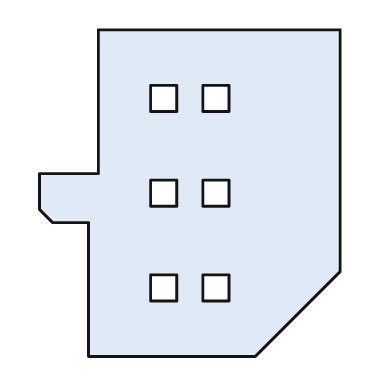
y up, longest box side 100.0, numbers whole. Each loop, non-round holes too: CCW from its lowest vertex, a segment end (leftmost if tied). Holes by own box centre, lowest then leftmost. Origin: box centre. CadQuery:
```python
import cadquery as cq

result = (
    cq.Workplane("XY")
    .moveTo(-31.0, -50.0)
    .lineTo(20.0, -50.0)
    .lineTo(46.0, -24.0)
    .lineTo(46.0, 50.0)
    .lineTo(-28.0, 50.0)
    .lineTo(-28.0, 6.0)
    .lineTo(-46.0, 6.0)
    .lineTo(-46.0, -5.0)
    .lineTo(-42.0, -9.0)
    .lineTo(-31.0, -9.0)
    .close()
    .moveTo(-12.0, -33.0)
    .lineTo(-4.0, -33.0)
    .lineTo(-4.0, -25.0)
    .lineTo(-12.0, -25.0)
    .close()
    .moveTo(4.0, -33.0)
    .lineTo(12.0, -33.0)
    .lineTo(12.0, -25.0)
    .lineTo(4.0, -25.0)
    .close()
    .moveTo(-12.0, -4.0)
    .lineTo(-4.0, -4.0)
    .lineTo(-4.0, 4.0)
    .lineTo(-12.0, 4.0)
    .close()
    .moveTo(4.0, -4.0)
    .lineTo(12.0, -4.0)
    .lineTo(12.0, 4.0)
    .lineTo(4.0, 4.0)
    .close()
    .moveTo(-12.0, 25.0)
    .lineTo(-4.0, 25.0)
    .lineTo(-4.0, 33.0)
    .lineTo(-12.0, 33.0)
    .close()
    .moveTo(4.0, 25.0)
    .lineTo(12.0, 25.0)
    .lineTo(12.0, 33.0)
    .lineTo(4.0, 33.0)
    .close()
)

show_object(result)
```